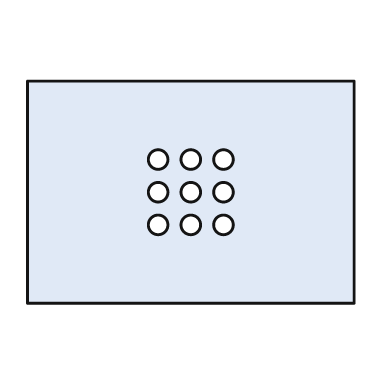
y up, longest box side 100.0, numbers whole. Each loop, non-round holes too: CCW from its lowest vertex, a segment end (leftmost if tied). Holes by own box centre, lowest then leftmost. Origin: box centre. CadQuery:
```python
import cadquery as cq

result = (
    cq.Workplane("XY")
    .moveTo(-50.0, -34.0)
    .lineTo(50.0, -34.0)
    .lineTo(50.0, 34.0)
    .lineTo(-50.0, 34.0)
    .close()
    .moveTo(-10.0, -10.0)
    .circle(3.0)
    .moveTo(0.0, -10.0)
    .circle(3.0)
    .moveTo(10.0, -10.0)
    .circle(3.0)
    .moveTo(-10.0, 0.0)
    .circle(3.0)
    .moveTo(0.0, 0.0)
    .circle(3.0)
    .moveTo(10.0, 0.0)
    .circle(3.0)
    .moveTo(-10.0, 10.0)
    .circle(3.0)
    .moveTo(0.0, 10.0)
    .circle(3.0)
    .moveTo(10.0, 10.0)
    .circle(3.0)
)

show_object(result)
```